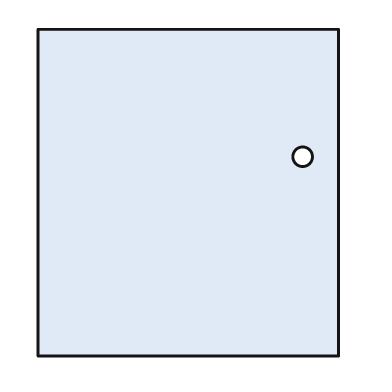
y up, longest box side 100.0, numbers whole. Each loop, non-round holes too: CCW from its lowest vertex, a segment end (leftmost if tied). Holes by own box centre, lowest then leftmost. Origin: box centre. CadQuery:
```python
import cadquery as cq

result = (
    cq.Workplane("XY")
    .moveTo(-46.0, -50.0)
    .lineTo(46.0, -50.0)
    .lineTo(46.0, 50.0)
    .lineTo(-46.0, 50.0)
    .close()
    .moveTo(35.0, 11.0)
    .circle(3.0)
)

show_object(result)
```